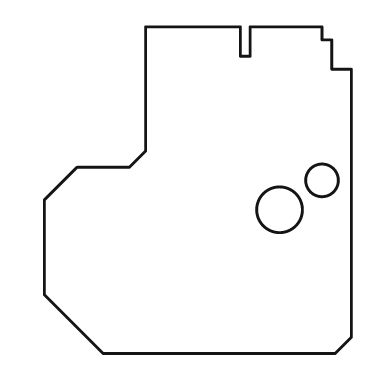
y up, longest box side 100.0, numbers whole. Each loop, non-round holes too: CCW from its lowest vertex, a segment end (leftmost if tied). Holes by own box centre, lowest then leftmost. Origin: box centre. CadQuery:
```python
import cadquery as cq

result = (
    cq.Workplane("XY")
    .moveTo(-29.0, -50.0)
    .lineTo(42.0, -50.0)
    .lineTo(47.0, -45.0)
    .lineTo(47.0, 37.0)
    .lineTo(41.0, 37.0)
    .lineTo(41.0, 46.0)
    .lineTo(38.0, 46.0)
    .lineTo(38.0, 50.0)
    .lineTo(16.0, 50.0)
    .lineTo(16.0, 41.0)
    .lineTo(13.0, 41.0)
    .lineTo(13.0, 50.0)
    .lineTo(-16.0, 50.0)
    .lineTo(-16.0, 12.0)
    .lineTo(-21.0, 7.0)
    .lineTo(-37.0, 7.0)
    .lineTo(-47.0, -3.0)
    .lineTo(-47.0, -32.0)
    .close()
    .moveTo(25.0, -6.0)
    .circle(7.0)
    .moveTo(38.0, 3.0)
    .circle(5.0)
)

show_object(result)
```